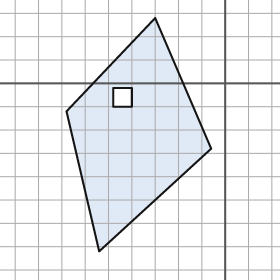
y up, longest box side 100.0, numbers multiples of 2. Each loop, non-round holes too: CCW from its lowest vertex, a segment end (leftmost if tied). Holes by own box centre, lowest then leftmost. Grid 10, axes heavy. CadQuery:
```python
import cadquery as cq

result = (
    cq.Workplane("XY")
    .moveTo(-54.0, -72.0)
    .lineTo(-6.0, -28.0)
    .lineTo(-30.0, 28.0)
    .lineTo(-68.0, -12.0)
    .close()
    .moveTo(-48.0, -10.0)
    .lineTo(-40.0, -10.0)
    .lineTo(-40.0, -2.0)
    .lineTo(-48.0, -2.0)
    .close()
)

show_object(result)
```